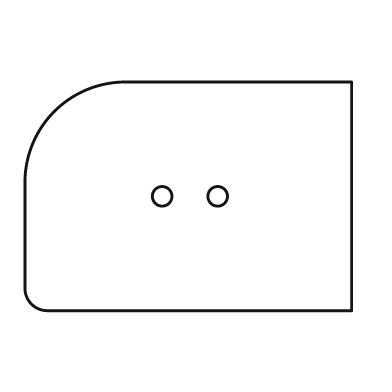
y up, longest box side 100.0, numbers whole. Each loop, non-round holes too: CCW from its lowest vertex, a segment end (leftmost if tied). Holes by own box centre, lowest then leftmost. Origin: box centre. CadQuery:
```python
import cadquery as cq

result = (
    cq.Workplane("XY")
    .moveTo(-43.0, -35.0)
    .lineTo(50.0, -35.0)
    .lineTo(50.0, 35.0)
    .lineTo(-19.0, 35.0)
    .threePointArc((-41.0, 26.0), (-50.0, 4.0))
    .lineTo(-50.0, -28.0)
    .threePointArc((-48.0, -33.0), (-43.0, -35.0))
    .close()
    .moveTo(-8.0, 0.0)
    .circle(3.0)
    .moveTo(9.0, 0.0)
    .circle(3.0)
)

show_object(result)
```